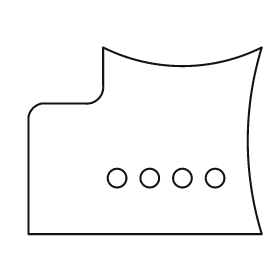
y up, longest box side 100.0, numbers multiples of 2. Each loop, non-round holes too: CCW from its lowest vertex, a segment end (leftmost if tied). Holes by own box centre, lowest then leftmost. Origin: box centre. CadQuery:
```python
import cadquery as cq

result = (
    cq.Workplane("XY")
    .moveTo(-50.0, -40.0)
    .lineTo(50.0, -40.0)
    .threePointArc((44.0, 0.0), (50.0, 40.0))
    .threePointArc((16.0, 32.0), (-18.0, 40.0))
    .lineTo(-18.0, 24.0)
    .threePointArc((-20.0, 18.0), (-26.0, 16.0))
    .lineTo(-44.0, 16.0)
    .threePointArc((-48.0, 14.0), (-50.0, 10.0))
    .close()
    .moveTo(-12.0, -16.0)
    .circle(4.0)
    .moveTo(2.0, -16.0)
    .circle(4.0)
    .moveTo(16.0, -16.0)
    .circle(4.0)
    .moveTo(30.0, -16.0)
    .circle(4.0)
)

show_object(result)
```